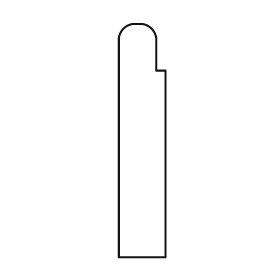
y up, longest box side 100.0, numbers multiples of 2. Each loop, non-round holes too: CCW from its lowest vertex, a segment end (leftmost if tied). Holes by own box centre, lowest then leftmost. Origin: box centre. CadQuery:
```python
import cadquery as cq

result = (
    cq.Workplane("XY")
    .moveTo(-10.0, -50.0)
    .lineTo(10.0, -50.0)
    .lineTo(10.0, 30.0)
    .lineTo(6.0, 30.0)
    .lineTo(6.0, 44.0)
    .threePointArc((4.0, 48.0), (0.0, 50.0))
    .lineTo(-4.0, 50.0)
    .threePointArc((-8.0, 48.0), (-10.0, 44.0))
    .close()
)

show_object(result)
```